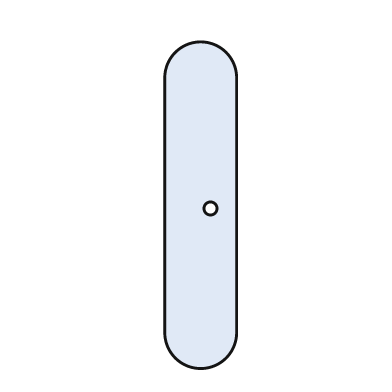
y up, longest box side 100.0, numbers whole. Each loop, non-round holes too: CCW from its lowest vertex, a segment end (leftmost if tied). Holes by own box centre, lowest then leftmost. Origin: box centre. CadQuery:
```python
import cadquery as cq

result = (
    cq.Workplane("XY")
    .moveTo(-11.0, -39.0)
    .threePointArc((0.0, -50.0), (11.0, -39.0))
    .lineTo(11.0, 39.0)
    .threePointArc((0.0, 50.0), (-11.0, 39.0))
    .close()
    .moveTo(3.0, -1.0)
    .circle(2.0)
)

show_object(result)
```